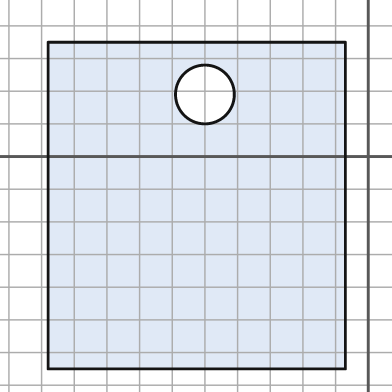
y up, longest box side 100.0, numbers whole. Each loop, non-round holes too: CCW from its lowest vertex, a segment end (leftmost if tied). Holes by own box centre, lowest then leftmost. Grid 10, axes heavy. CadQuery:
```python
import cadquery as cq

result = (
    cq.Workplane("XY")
    .moveTo(-98.0, -65.0)
    .lineTo(-7.0, -65.0)
    .lineTo(-7.0, 35.0)
    .lineTo(-98.0, 35.0)
    .close()
    .moveTo(-50.0, 19.0)
    .circle(9.0)
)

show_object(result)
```